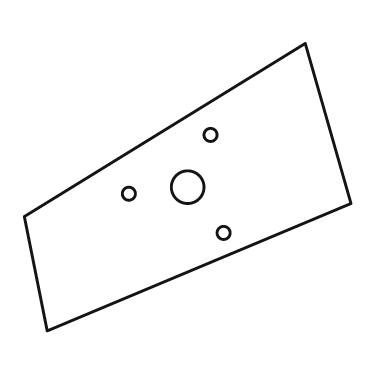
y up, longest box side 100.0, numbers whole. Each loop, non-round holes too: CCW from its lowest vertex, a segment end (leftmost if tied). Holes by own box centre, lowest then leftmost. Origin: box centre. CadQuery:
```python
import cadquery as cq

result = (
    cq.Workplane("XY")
    .moveTo(-43.0, -44.0)
    .lineTo(50.0, -5.0)
    .lineTo(36.0, 44.0)
    .lineTo(-50.0, -9.0)
    .close()
    .moveTo(11.0, -14.0)
    .circle(2.0)
    .moveTo(-18.0, -2.0)
    .circle(2.0)
    .moveTo(0.0, 0.0)
    .circle(5.0)
    .moveTo(7.0, 16.0)
    .circle(2.0)
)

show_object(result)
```